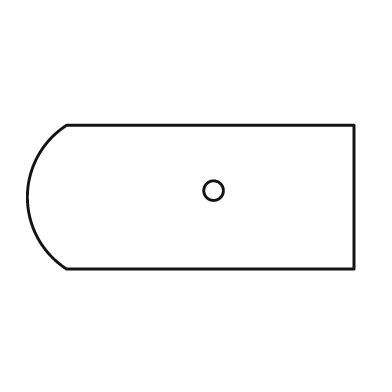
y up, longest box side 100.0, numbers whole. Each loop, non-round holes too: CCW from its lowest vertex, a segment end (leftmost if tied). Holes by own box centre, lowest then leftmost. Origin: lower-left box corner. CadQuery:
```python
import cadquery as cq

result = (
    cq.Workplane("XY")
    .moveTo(12.0, 0.0)
    .lineTo(100.0, 0.0)
    .lineTo(100.0, 44.0)
    .lineTo(12.0, 44.0)
    .threePointArc((0.0, 22.0), (12.0, 0.0))
    .close()
    .moveTo(57.0, 24.0)
    .circle(3.0)
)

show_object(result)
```